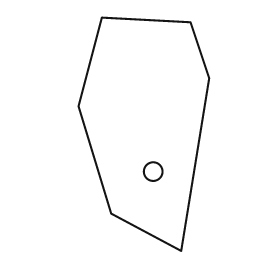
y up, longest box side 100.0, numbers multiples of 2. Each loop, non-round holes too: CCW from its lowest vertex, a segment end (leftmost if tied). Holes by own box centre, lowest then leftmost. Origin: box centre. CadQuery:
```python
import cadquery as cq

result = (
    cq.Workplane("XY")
    .moveTo(16.0, -50.0)
    .lineTo(28.0, 24.0)
    .lineTo(20.0, 48.0)
    .lineTo(-18.0, 50.0)
    .lineTo(-28.0, 12.0)
    .lineTo(-14.0, -34.0)
    .close()
    .moveTo(4.0, -16.0)
    .circle(4.0)
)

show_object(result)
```